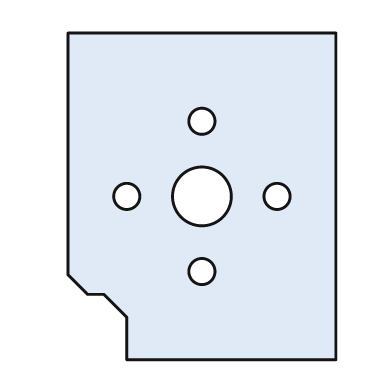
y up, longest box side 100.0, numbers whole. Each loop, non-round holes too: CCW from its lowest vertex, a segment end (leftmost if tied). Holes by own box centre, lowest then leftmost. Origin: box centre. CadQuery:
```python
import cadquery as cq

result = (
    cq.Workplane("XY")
    .moveTo(-23.0, -50.0)
    .lineTo(41.0, -50.0)
    .lineTo(41.0, 50.0)
    .lineTo(-41.0, 50.0)
    .lineTo(-41.0, -24.0)
    .lineTo(-35.0, -30.0)
    .lineTo(-30.0, -30.0)
    .lineTo(-23.0, -37.0)
    .close()
    .moveTo(0.0, -23.0)
    .circle(4.0)
    .moveTo(-23.0, 0.0)
    .circle(4.0)
    .moveTo(0.0, 0.0)
    .circle(9.0)
    .moveTo(23.0, 0.0)
    .circle(4.0)
    .moveTo(0.0, 23.0)
    .circle(4.0)
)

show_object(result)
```